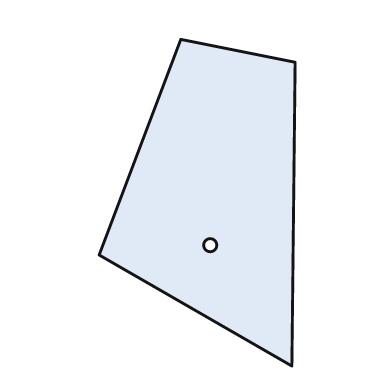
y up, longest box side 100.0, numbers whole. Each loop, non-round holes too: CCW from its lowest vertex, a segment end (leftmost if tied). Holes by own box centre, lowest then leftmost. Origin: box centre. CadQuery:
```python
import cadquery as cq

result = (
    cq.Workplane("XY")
    .moveTo(29.0, -50.0)
    .lineTo(30.0, 43.0)
    .lineTo(-5.0, 50.0)
    .lineTo(-30.0, -16.0)
    .close()
    .moveTo(4.0, -13.0)
    .circle(2.0)
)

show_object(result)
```